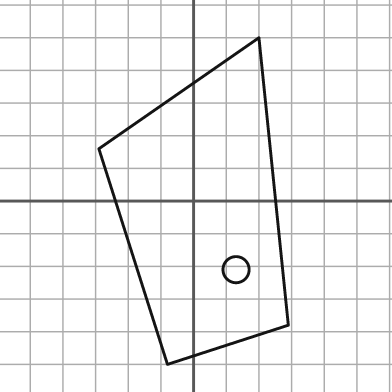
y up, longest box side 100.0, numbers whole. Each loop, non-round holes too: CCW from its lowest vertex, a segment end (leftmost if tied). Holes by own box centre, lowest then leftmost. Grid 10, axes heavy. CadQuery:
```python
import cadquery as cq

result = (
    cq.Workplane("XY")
    .moveTo(-8.0, -50.0)
    .lineTo(29.0, -38.0)
    .lineTo(20.0, 50.0)
    .lineTo(-29.0, 16.0)
    .close()
    .moveTo(13.0, -21.0)
    .circle(4.0)
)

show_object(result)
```